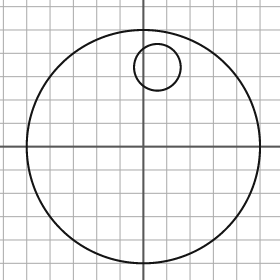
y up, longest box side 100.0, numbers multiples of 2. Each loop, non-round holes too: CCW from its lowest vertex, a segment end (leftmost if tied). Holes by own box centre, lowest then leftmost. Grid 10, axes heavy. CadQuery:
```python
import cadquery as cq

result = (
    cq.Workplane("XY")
    .moveTo(0.0, 0.0)
    .circle(50.0)
    .moveTo(6.0, 34.0)
    .circle(10.0)
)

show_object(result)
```